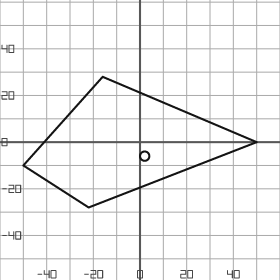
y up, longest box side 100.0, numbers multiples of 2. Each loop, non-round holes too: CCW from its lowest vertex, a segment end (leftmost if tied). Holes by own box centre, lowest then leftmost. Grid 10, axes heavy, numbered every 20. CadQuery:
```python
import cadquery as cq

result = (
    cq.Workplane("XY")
    .moveTo(-22.0, -28.0)
    .lineTo(50.0, 0.0)
    .lineTo(-16.0, 28.0)
    .lineTo(-50.0, -10.0)
    .close()
    .moveTo(2.0, -6.0)
    .circle(2.0)
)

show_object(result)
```